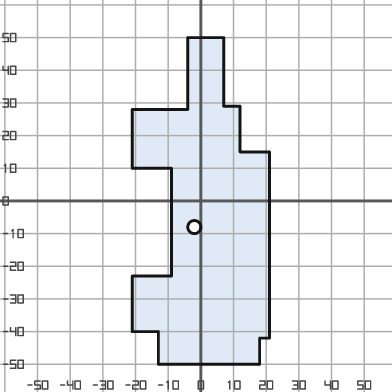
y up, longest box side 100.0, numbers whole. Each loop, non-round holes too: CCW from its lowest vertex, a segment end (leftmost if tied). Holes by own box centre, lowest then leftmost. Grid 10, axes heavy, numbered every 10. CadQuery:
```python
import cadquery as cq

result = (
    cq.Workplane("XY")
    .moveTo(-13.0, -50.0)
    .lineTo(18.0, -50.0)
    .lineTo(18.0, -42.0)
    .lineTo(21.0, -42.0)
    .lineTo(21.0, 15.0)
    .lineTo(12.0, 15.0)
    .lineTo(12.0, 29.0)
    .lineTo(7.0, 29.0)
    .lineTo(7.0, 50.0)
    .lineTo(-4.0, 50.0)
    .lineTo(-4.0, 28.0)
    .lineTo(-21.0, 28.0)
    .lineTo(-21.0, 10.0)
    .lineTo(-9.0, 10.0)
    .lineTo(-9.0, -23.0)
    .lineTo(-21.0, -23.0)
    .lineTo(-21.0, -40.0)
    .lineTo(-13.0, -40.0)
    .close()
    .moveTo(-2.0, -8.0)
    .circle(2.0)
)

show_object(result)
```